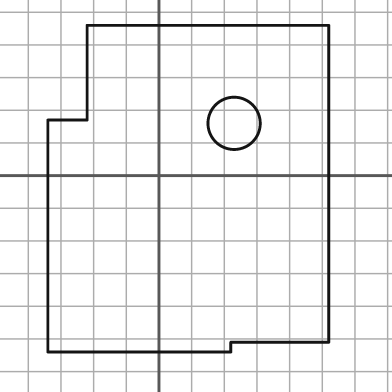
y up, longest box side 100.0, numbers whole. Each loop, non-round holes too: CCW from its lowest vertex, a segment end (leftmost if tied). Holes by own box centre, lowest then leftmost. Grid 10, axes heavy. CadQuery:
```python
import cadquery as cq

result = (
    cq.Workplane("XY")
    .moveTo(-34.0, -54.0)
    .lineTo(22.0, -54.0)
    .lineTo(22.0, -51.0)
    .lineTo(52.0, -51.0)
    .lineTo(52.0, 46.0)
    .lineTo(-22.0, 46.0)
    .lineTo(-22.0, 17.0)
    .lineTo(-34.0, 17.0)
    .close()
    .moveTo(23.0, 16.0)
    .circle(8.0)
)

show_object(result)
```